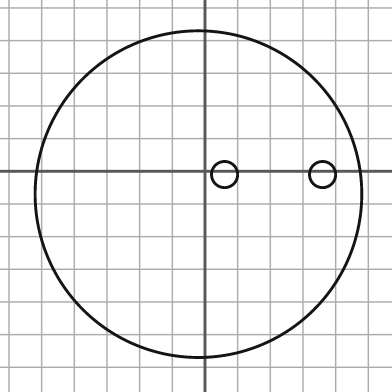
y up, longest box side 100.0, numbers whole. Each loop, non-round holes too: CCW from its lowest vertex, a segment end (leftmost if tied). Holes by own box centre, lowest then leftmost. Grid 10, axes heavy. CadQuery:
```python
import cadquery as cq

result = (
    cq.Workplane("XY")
    .moveTo(-2.0, -7.0)
    .circle(50.0)
    .moveTo(6.0, -1.0)
    .circle(4.0)
    .moveTo(36.0, -1.0)
    .circle(4.0)
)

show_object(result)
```